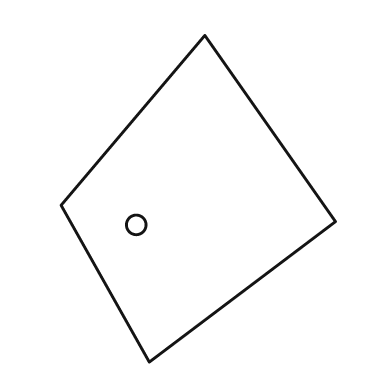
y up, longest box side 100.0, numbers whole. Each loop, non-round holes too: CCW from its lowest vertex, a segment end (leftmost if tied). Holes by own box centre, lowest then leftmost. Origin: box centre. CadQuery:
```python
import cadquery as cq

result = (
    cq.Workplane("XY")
    .moveTo(-15.0, -50.0)
    .lineTo(42.0, -7.0)
    .lineTo(2.0, 50.0)
    .lineTo(-42.0, -2.0)
    .close()
    .moveTo(-19.0, -8.0)
    .circle(3.0)
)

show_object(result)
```